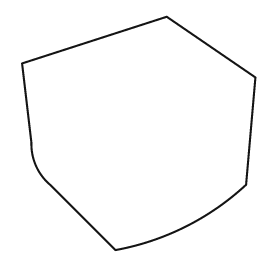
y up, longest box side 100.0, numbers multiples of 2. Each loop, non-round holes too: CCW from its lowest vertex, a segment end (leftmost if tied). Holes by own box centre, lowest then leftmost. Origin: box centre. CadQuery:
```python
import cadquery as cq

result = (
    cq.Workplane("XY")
    .moveTo(-10.0, -50.0)
    .threePointArc((20.0, -40.0), (46.0, -22.0))
    .lineTo(50.0, 24.0)
    .lineTo(12.0, 50.0)
    .lineTo(-50.0, 30.0)
    .lineTo(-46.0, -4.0)
    .threePointArc((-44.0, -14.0), (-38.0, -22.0))
    .close()
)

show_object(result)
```